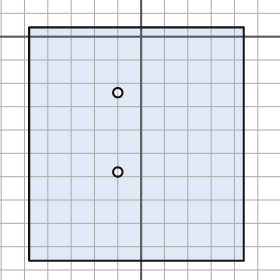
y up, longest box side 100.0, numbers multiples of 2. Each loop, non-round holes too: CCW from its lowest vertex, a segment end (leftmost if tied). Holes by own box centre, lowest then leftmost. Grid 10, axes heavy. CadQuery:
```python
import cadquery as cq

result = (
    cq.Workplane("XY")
    .moveTo(-48.0, -96.0)
    .lineTo(44.0, -96.0)
    .lineTo(44.0, 4.0)
    .lineTo(-48.0, 4.0)
    .close()
    .moveTo(-10.0, -58.0)
    .circle(2.0)
    .moveTo(-10.0, -24.0)
    .circle(2.0)
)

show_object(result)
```